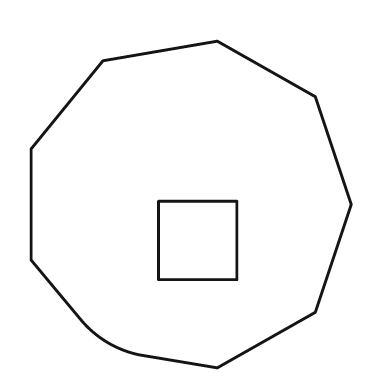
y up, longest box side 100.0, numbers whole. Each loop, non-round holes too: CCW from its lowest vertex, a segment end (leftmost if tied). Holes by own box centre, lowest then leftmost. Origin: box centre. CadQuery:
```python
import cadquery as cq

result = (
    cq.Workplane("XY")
    .moveTo(8.0, -50.0)
    .lineTo(38.0, -33.0)
    .lineTo(49.0, 0.0)
    .lineTo(38.0, 33.0)
    .lineTo(8.0, 50.0)
    .lineTo(-27.0, 44.0)
    .lineTo(-49.0, 17.0)
    .lineTo(-49.0, -17.0)
    .lineTo(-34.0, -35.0)
    .threePointArc((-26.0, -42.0), (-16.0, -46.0))
    .close()
    .moveTo(-10.0, -23.0)
    .lineTo(14.0, -23.0)
    .lineTo(14.0, 1.0)
    .lineTo(-10.0, 1.0)
    .close()
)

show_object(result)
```